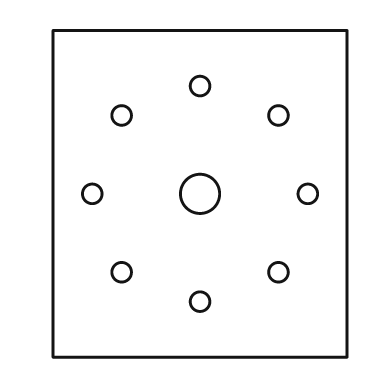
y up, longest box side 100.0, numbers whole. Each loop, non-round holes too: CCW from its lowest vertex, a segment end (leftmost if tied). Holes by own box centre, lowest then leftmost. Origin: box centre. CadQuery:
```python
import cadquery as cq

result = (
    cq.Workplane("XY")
    .moveTo(-45.0, -50.0)
    .lineTo(45.0, -50.0)
    .lineTo(45.0, 50.0)
    .lineTo(-45.0, 50.0)
    .close()
    .moveTo(0.0, -33.0)
    .circle(3.0)
    .moveTo(-24.0, -24.0)
    .circle(3.0)
    .moveTo(24.0, -24.0)
    .circle(3.0)
    .moveTo(-33.0, 0.0)
    .circle(3.0)
    .moveTo(0.0, 0.0)
    .circle(6.0)
    .moveTo(33.0, 0.0)
    .circle(3.0)
    .moveTo(-24.0, 24.0)
    .circle(3.0)
    .moveTo(24.0, 24.0)
    .circle(3.0)
    .moveTo(0.0, 33.0)
    .circle(3.0)
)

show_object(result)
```